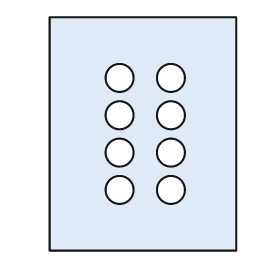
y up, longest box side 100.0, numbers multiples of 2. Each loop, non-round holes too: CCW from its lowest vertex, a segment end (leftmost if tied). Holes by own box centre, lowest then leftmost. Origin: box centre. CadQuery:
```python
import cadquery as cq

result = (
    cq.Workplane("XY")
    .moveTo(-40.0, -50.0)
    .lineTo(40.0, -50.0)
    .lineTo(40.0, 50.0)
    .lineTo(-40.0, 50.0)
    .close()
    .moveTo(-10.0, -24.0)
    .circle(6.0)
    .moveTo(12.0, -24.0)
    .circle(6.0)
    .moveTo(-10.0, -8.0)
    .circle(6.0)
    .moveTo(12.0, -8.0)
    .circle(6.0)
    .moveTo(-10.0, 8.0)
    .circle(6.0)
    .moveTo(12.0, 8.0)
    .circle(6.0)
    .moveTo(-10.0, 24.0)
    .circle(6.0)
    .moveTo(12.0, 24.0)
    .circle(6.0)
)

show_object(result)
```